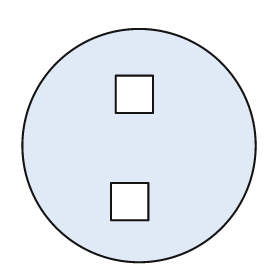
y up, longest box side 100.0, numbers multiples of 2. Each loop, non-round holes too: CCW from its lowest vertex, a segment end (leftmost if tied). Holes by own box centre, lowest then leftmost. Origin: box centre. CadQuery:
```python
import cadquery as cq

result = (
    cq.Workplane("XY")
    .moveTo(0.0, 0.0)
    .circle(50.0)
    .moveTo(-12.0, -32.0)
    .lineTo(4.0, -32.0)
    .lineTo(4.0, -16.0)
    .lineTo(-12.0, -16.0)
    .close()
    .moveTo(-10.0, 14.0)
    .lineTo(6.0, 14.0)
    .lineTo(6.0, 30.0)
    .lineTo(-10.0, 30.0)
    .close()
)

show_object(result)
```